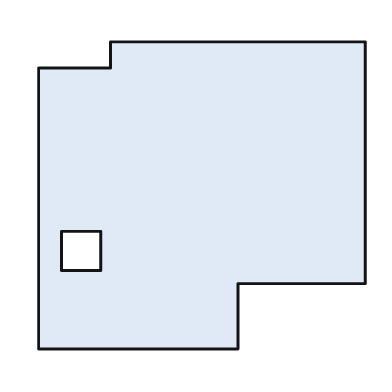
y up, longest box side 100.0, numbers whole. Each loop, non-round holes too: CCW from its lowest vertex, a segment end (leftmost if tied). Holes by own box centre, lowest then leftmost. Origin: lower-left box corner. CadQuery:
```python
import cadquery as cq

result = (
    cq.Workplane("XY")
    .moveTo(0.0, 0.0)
    .lineTo(61.0, 0.0)
    .lineTo(61.0, 20.0)
    .lineTo(100.0, 20.0)
    .lineTo(100.0, 94.0)
    .lineTo(22.0, 94.0)
    .lineTo(22.0, 86.0)
    .lineTo(0.0, 86.0)
    .close()
    .moveTo(7.0, 24.0)
    .lineTo(19.0, 24.0)
    .lineTo(19.0, 36.0)
    .lineTo(7.0, 36.0)
    .close()
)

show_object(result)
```